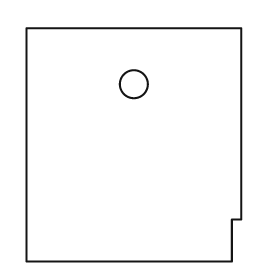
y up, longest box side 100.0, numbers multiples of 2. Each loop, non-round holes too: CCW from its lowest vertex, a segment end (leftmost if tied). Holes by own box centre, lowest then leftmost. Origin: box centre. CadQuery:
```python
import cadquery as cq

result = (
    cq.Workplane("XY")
    .moveTo(-46.0, -50.0)
    .lineTo(42.0, -50.0)
    .lineTo(42.0, -32.0)
    .lineTo(46.0, -32.0)
    .lineTo(46.0, 50.0)
    .lineTo(-46.0, 50.0)
    .close()
    .moveTo(0.0, 26.0)
    .circle(6.0)
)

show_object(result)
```